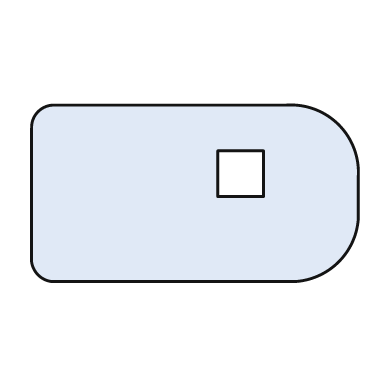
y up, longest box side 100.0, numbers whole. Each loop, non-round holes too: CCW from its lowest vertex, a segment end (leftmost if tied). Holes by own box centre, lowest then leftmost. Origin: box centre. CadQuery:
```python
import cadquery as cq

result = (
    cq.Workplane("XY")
    .moveTo(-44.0, -27.0)
    .lineTo(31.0, -27.0)
    .threePointArc((44.0, -21.0), (50.0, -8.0))
    .lineTo(50.0, 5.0)
    .threePointArc((44.0, 21.0), (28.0, 27.0))
    .lineTo(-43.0, 27.0)
    .threePointArc((-48.0, 25.0), (-50.0, 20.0))
    .lineTo(-50.0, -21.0)
    .threePointArc((-48.0, -25.0), (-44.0, -27.0))
    .close()
    .moveTo(7.0, -1.0)
    .lineTo(21.0, -1.0)
    .lineTo(21.0, 13.0)
    .lineTo(7.0, 13.0)
    .close()
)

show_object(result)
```